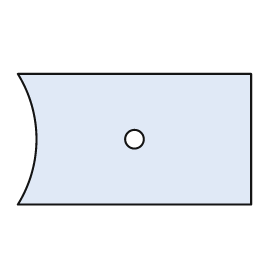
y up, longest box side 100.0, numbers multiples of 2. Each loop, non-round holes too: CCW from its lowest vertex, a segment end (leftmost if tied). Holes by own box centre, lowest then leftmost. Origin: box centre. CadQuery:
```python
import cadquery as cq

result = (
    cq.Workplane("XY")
    .moveTo(-50.0, -28.0)
    .lineTo(50.0, -28.0)
    .lineTo(50.0, 28.0)
    .lineTo(-50.0, 28.0)
    .threePointArc((-42.0, 0.0), (-50.0, -28.0))
    .close()
    .moveTo(0.0, 0.0)
    .circle(4.0)
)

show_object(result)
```